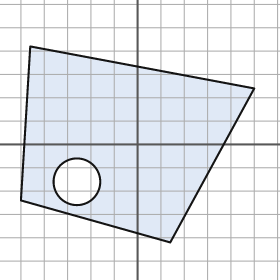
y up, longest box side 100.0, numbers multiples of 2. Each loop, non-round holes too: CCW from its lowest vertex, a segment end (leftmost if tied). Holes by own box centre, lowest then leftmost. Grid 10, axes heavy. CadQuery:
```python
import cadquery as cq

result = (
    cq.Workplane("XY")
    .moveTo(14.0, -42.0)
    .lineTo(50.0, 24.0)
    .lineTo(-46.0, 42.0)
    .lineTo(-50.0, -24.0)
    .close()
    .moveTo(-26.0, -16.0)
    .circle(10.0)
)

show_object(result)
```